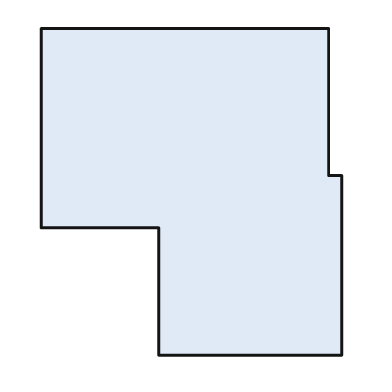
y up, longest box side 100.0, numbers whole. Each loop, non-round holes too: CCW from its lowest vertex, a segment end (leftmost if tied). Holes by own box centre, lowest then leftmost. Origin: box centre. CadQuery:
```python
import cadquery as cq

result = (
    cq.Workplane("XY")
    .moveTo(-10.0, -50.0)
    .lineTo(46.0, -50.0)
    .lineTo(46.0, 5.0)
    .lineTo(42.0, 5.0)
    .lineTo(42.0, 50.0)
    .lineTo(-46.0, 50.0)
    .lineTo(-46.0, -11.0)
    .lineTo(-10.0, -11.0)
    .close()
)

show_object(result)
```